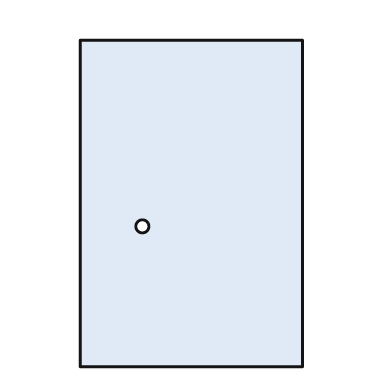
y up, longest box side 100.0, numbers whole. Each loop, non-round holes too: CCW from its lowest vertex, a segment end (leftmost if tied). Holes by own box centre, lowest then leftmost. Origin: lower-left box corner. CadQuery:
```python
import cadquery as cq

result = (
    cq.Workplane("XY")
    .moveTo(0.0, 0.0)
    .lineTo(68.0, 0.0)
    .lineTo(68.0, 100.0)
    .lineTo(0.0, 100.0)
    .close()
    .moveTo(19.0, 43.0)
    .circle(2.0)
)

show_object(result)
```